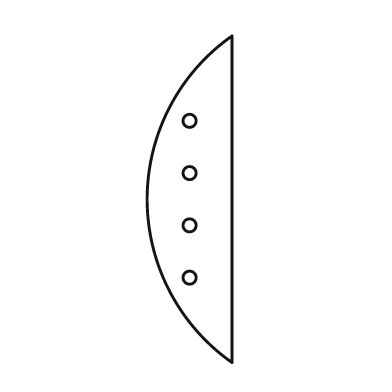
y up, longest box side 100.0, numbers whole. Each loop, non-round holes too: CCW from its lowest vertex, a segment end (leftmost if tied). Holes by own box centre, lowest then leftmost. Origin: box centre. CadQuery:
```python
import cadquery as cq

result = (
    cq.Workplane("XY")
    .moveTo(13.0, -50.0)
    .lineTo(13.0, 50.0)
    .threePointArc((-13.0, 0.0), (13.0, -50.0))
    .close()
    .moveTo(0.0, -24.0)
    .circle(2.0)
    .moveTo(0.0, -8.0)
    .circle(2.0)
    .moveTo(0.0, 8.0)
    .circle(2.0)
    .moveTo(0.0, 24.0)
    .circle(2.0)
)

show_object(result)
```